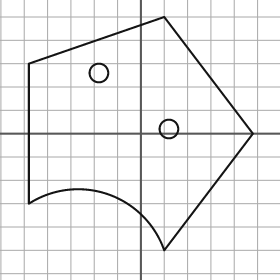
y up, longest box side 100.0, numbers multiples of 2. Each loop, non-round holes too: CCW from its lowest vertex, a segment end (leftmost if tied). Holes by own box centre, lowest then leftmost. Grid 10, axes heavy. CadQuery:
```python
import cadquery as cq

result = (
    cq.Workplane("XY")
    .moveTo(10.0, -50.0)
    .lineTo(48.0, 0.0)
    .lineTo(10.0, 50.0)
    .lineTo(-48.0, 30.0)
    .lineTo(-48.0, -30.0)
    .threePointArc((-14.0, -26.0), (10.0, -50.0))
    .close()
    .moveTo(12.0, 2.0)
    .circle(4.0)
    .moveTo(-18.0, 26.0)
    .circle(4.0)
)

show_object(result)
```